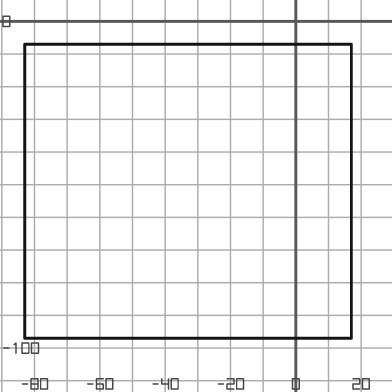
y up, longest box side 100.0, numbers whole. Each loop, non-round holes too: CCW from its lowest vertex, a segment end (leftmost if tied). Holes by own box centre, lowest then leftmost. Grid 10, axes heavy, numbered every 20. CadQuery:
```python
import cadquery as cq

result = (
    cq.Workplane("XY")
    .moveTo(-83.0, -97.0)
    .lineTo(17.0, -97.0)
    .lineTo(17.0, -7.0)
    .lineTo(-83.0, -7.0)
    .close()
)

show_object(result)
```